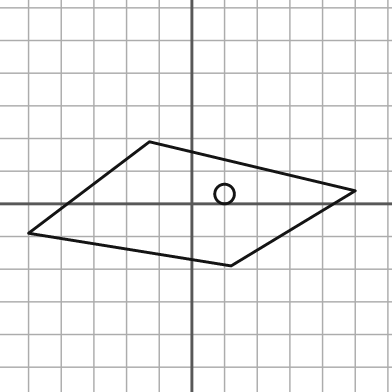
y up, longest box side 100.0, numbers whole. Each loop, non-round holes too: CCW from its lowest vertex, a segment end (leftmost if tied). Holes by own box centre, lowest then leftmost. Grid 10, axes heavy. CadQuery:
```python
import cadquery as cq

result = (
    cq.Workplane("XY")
    .moveTo(12.0, -19.0)
    .lineTo(50.0, 4.0)
    .lineTo(-13.0, 19.0)
    .lineTo(-50.0, -9.0)
    .close()
    .moveTo(10.0, 3.0)
    .circle(3.0)
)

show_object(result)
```